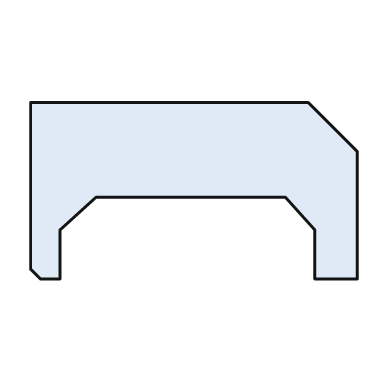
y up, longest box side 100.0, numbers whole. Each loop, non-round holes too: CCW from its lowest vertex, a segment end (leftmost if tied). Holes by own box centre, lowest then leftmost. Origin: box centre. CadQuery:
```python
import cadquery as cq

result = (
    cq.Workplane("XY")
    .moveTo(-47.0, -27.0)
    .lineTo(-41.0, -27.0)
    .lineTo(-41.0, -12.0)
    .lineTo(-30.0, -2.0)
    .lineTo(28.0, -2.0)
    .lineTo(37.0, -12.0)
    .lineTo(37.0, -27.0)
    .lineTo(50.0, -27.0)
    .lineTo(50.0, 12.0)
    .lineTo(35.0, 27.0)
    .lineTo(-50.0, 27.0)
    .lineTo(-50.0, -24.0)
    .close()
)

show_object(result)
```